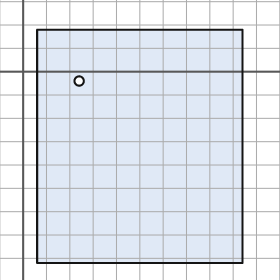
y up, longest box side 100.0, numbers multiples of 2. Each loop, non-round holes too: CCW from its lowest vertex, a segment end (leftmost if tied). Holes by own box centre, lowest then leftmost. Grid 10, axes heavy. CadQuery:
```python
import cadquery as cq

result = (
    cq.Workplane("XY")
    .moveTo(6.0, -82.0)
    .lineTo(94.0, -82.0)
    .lineTo(94.0, 18.0)
    .lineTo(6.0, 18.0)
    .close()
    .moveTo(24.0, -4.0)
    .circle(2.0)
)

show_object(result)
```